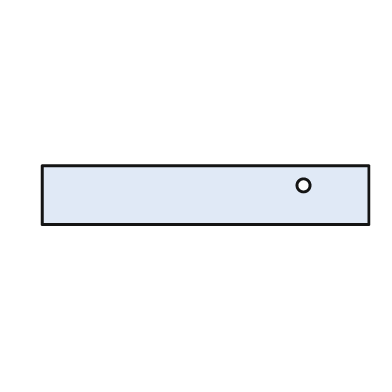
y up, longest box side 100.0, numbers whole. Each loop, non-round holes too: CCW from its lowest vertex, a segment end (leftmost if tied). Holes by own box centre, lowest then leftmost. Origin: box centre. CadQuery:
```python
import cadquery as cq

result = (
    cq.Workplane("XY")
    .moveTo(-50.0, -9.0)
    .lineTo(50.0, -9.0)
    .lineTo(50.0, 9.0)
    .lineTo(-50.0, 9.0)
    .close()
    .moveTo(30.0, 3.0)
    .circle(2.0)
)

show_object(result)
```